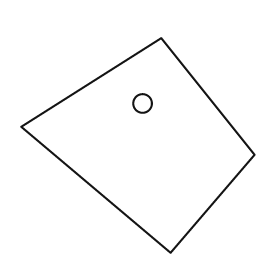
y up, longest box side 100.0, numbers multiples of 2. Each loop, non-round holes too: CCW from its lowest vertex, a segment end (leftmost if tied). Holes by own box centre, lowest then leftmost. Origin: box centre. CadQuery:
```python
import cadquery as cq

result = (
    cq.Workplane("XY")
    .moveTo(14.0, -46.0)
    .lineTo(50.0, -4.0)
    .lineTo(10.0, 46.0)
    .lineTo(-50.0, 8.0)
    .close()
    .moveTo(2.0, 18.0)
    .circle(4.0)
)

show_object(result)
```